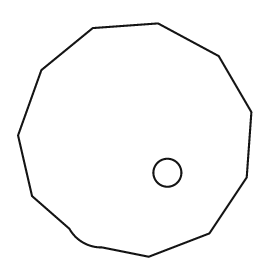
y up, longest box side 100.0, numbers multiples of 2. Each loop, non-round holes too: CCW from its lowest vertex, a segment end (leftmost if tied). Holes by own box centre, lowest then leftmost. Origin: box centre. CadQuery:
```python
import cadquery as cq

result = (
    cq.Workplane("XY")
    .moveTo(6.0, -50.0)
    .lineTo(32.0, -40.0)
    .lineTo(48.0, -16.0)
    .lineTo(50.0, 12.0)
    .lineTo(36.0, 36.0)
    .lineTo(10.0, 50.0)
    .lineTo(-18.0, 48.0)
    .lineTo(-40.0, 30.0)
    .lineTo(-50.0, 2.0)
    .lineTo(-44.0, -24.0)
    .lineTo(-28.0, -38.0)
    .threePointArc((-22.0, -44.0), (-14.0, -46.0))
    .close()
    .moveTo(14.0, -14.0)
    .circle(6.0)
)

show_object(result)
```